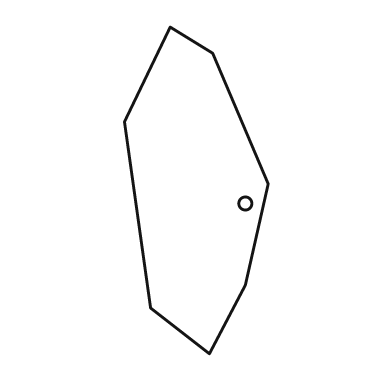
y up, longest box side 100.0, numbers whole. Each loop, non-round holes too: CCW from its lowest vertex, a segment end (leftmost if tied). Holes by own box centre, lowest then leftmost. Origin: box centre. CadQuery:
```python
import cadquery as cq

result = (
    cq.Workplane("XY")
    .moveTo(4.0, -50.0)
    .lineTo(15.0, -29.0)
    .lineTo(22.0, 2.0)
    .lineTo(5.0, 42.0)
    .lineTo(-8.0, 50.0)
    .lineTo(-22.0, 21.0)
    .lineTo(-14.0, -36.0)
    .close()
    .moveTo(15.0, -4.0)
    .circle(2.0)
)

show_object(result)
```